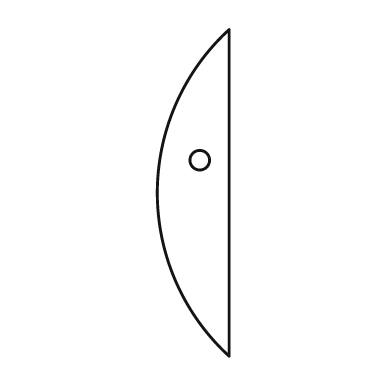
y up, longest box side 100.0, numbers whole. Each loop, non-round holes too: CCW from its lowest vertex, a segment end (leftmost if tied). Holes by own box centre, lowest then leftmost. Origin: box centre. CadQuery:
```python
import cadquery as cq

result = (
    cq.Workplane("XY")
    .moveTo(11.0, -50.0)
    .lineTo(11.0, 50.0)
    .threePointArc((-11.0, 0.0), (11.0, -50.0))
    .close()
    .moveTo(2.0, 10.0)
    .circle(3.0)
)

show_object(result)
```